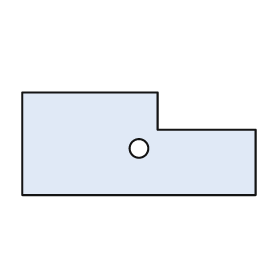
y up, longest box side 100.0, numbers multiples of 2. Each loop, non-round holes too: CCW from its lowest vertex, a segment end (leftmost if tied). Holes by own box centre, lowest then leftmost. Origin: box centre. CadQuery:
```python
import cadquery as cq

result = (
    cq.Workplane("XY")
    .moveTo(-50.0, -22.0)
    .lineTo(50.0, -22.0)
    .lineTo(50.0, 6.0)
    .lineTo(8.0, 6.0)
    .lineTo(8.0, 22.0)
    .lineTo(-50.0, 22.0)
    .close()
    .moveTo(0.0, -2.0)
    .circle(4.0)
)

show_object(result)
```